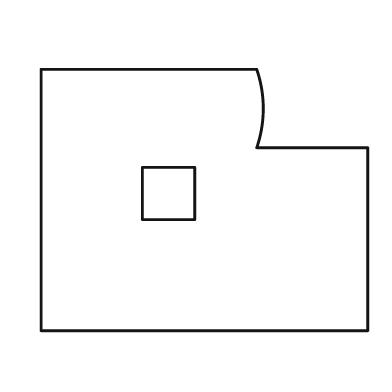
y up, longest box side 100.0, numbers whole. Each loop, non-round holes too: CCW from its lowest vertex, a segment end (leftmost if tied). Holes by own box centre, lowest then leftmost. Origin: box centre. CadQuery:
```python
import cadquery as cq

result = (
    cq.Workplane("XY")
    .moveTo(-50.0, -40.0)
    .lineTo(50.0, -40.0)
    .lineTo(50.0, 16.0)
    .lineTo(16.0, 16.0)
    .threePointArc((18.0, 28.0), (16.0, 40.0))
    .lineTo(-50.0, 40.0)
    .close()
    .moveTo(-19.0, -6.0)
    .lineTo(-3.0, -6.0)
    .lineTo(-3.0, 10.0)
    .lineTo(-19.0, 10.0)
    .close()
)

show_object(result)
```